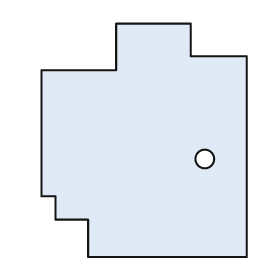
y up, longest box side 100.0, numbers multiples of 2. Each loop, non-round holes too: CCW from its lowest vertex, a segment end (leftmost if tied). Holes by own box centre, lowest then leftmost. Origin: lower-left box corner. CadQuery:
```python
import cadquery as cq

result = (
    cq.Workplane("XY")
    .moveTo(20.0, 0.0)
    .lineTo(88.0, 0.0)
    .lineTo(88.0, 86.0)
    .lineTo(64.0, 86.0)
    .lineTo(64.0, 100.0)
    .lineTo(32.0, 100.0)
    .lineTo(32.0, 80.0)
    .lineTo(0.0, 80.0)
    .lineTo(0.0, 26.0)
    .lineTo(6.0, 26.0)
    .lineTo(6.0, 16.0)
    .lineTo(20.0, 16.0)
    .close()
    .moveTo(70.0, 42.0)
    .circle(4.0)
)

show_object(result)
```